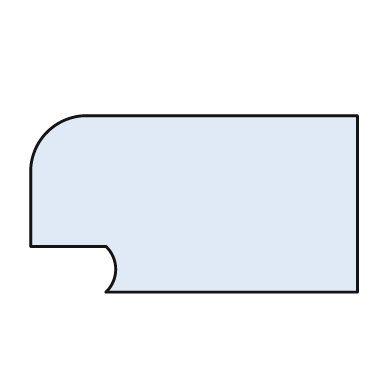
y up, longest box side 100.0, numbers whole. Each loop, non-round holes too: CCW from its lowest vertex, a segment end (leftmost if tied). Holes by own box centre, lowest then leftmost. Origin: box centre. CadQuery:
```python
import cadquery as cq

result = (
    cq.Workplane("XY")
    .moveTo(-27.0, -27.0)
    .lineTo(50.0, -27.0)
    .lineTo(50.0, 27.0)
    .lineTo(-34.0, 27.0)
    .threePointArc((-45.0, 22.0), (-50.0, 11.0))
    .lineTo(-50.0, -13.0)
    .lineTo(-27.0, -13.0)
    .threePointArc((-24.0, -20.0), (-27.0, -27.0))
    .close()
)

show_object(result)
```